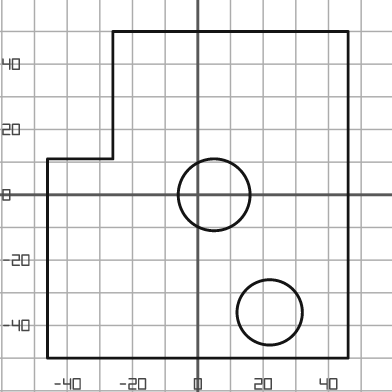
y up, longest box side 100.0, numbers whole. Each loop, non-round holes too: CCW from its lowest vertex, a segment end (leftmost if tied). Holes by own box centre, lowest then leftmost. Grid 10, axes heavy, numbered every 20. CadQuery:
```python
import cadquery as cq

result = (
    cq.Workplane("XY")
    .moveTo(-46.0, -50.0)
    .lineTo(46.0, -50.0)
    .lineTo(46.0, 50.0)
    .lineTo(-26.0, 50.0)
    .lineTo(-26.0, 11.0)
    .lineTo(-46.0, 11.0)
    .close()
    .moveTo(22.0, -36.0)
    .circle(10.0)
    .moveTo(5.0, 0.0)
    .circle(11.0)
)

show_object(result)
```